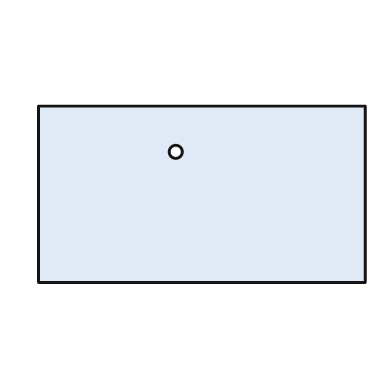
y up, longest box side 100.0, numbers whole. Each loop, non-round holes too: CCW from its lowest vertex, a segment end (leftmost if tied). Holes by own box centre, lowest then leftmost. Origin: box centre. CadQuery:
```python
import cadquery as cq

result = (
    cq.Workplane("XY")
    .moveTo(-50.0, -27.0)
    .lineTo(50.0, -27.0)
    .lineTo(50.0, 27.0)
    .lineTo(-50.0, 27.0)
    .close()
    .moveTo(-8.0, 13.0)
    .circle(2.0)
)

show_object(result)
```